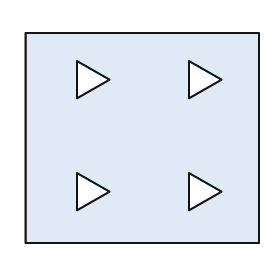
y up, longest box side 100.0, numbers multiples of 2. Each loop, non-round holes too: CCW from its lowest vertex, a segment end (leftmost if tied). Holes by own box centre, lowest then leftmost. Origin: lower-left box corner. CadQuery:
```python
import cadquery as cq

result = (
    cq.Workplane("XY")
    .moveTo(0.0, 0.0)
    .lineTo(100.0, 0.0)
    .lineTo(100.0, 90.0)
    .lineTo(0.0, 90.0)
    .close()
    .moveTo(22.0, 14.0)
    .lineTo(36.0, 22.0)
    .lineTo(22.0, 30.0)
    .close()
    .moveTo(70.0, 14.0)
    .lineTo(84.0, 22.0)
    .lineTo(70.0, 30.0)
    .close()
    .moveTo(22.0, 62.0)
    .lineTo(36.0, 70.0)
    .lineTo(22.0, 78.0)
    .close()
    .moveTo(70.0, 62.0)
    .lineTo(84.0, 70.0)
    .lineTo(70.0, 78.0)
    .close()
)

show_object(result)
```